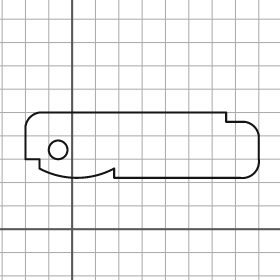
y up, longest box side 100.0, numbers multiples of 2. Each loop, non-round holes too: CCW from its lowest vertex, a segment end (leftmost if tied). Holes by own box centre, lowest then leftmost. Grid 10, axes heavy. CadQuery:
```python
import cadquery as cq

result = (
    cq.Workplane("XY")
    .moveTo(18.0, 22.0)
    .lineTo(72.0, 22.0)
    .threePointArc((78.0, 24.0), (80.0, 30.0))
    .lineTo(80.0, 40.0)
    .threePointArc((78.0, 44.0), (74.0, 46.0))
    .lineTo(66.0, 46.0)
    .lineTo(66.0, 50.0)
    .lineTo(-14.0, 50.0)
    .threePointArc((-18.0, 48.0), (-20.0, 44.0))
    .lineTo(-20.0, 30.0)
    .lineTo(-14.0, 30.0)
    .lineTo(-14.0, 26.0)
    .threePointArc((2.0, 22.0), (18.0, 26.0))
    .close()
    .moveTo(-6.0, 34.0)
    .circle(4.0)
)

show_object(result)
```